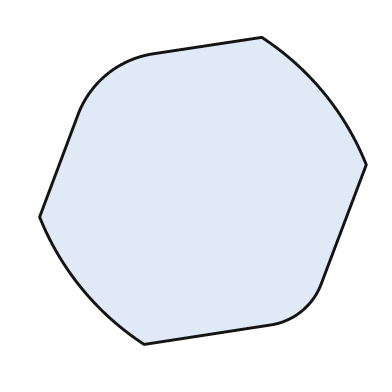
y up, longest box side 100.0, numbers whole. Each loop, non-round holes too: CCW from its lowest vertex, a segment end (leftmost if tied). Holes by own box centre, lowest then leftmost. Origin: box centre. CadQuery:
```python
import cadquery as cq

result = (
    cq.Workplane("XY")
    .moveTo(-18.0, -47.0)
    .lineTo(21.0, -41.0)
    .threePointArc((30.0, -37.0), (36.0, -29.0))
    .lineTo(50.0, 8.0)
    .threePointArc((37.0, 30.0), (18.0, 47.0))
    .lineTo(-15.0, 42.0)
    .threePointArc((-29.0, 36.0), (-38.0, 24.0))
    .lineTo(-50.0, -8.0)
    .threePointArc((-37.0, -30.0), (-18.0, -47.0))
    .close()
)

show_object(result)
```